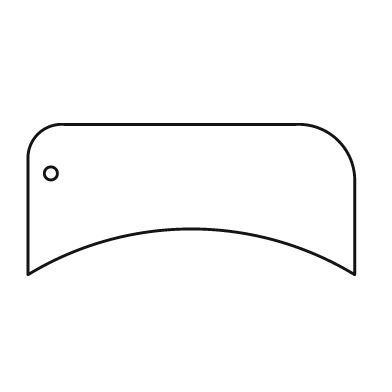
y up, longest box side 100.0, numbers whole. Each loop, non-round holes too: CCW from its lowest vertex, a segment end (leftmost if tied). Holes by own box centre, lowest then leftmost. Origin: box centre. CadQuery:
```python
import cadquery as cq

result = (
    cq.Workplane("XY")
    .moveTo(-50.0, -23.0)
    .threePointArc((0.0, -9.0), (50.0, -23.0))
    .lineTo(50.0, 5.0)
    .threePointArc((45.0, 18.0), (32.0, 23.0))
    .lineTo(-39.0, 23.0)
    .threePointArc((-47.0, 20.0), (-50.0, 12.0))
    .close()
    .moveTo(-43.0, 8.0)
    .circle(2.0)
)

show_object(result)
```